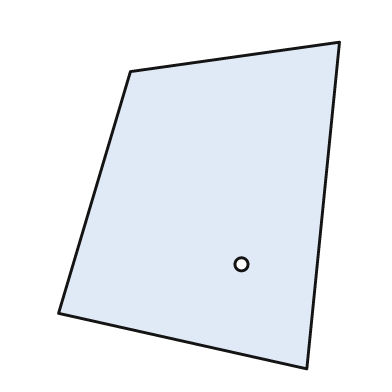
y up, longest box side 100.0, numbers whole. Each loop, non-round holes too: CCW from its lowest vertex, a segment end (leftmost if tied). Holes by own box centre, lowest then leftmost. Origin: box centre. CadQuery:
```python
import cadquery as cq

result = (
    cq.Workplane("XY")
    .moveTo(33.0, -50.0)
    .lineTo(43.0, 50.0)
    .lineTo(-21.0, 41.0)
    .lineTo(-43.0, -33.0)
    .close()
    .moveTo(13.0, -18.0)
    .circle(2.0)
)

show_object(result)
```